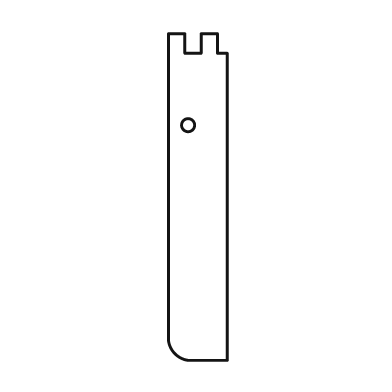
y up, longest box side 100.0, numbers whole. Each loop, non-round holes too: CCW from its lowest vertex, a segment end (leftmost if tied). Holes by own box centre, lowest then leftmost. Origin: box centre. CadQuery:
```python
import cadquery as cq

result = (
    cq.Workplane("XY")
    .moveTo(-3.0, -50.0)
    .lineTo(9.0, -50.0)
    .lineTo(9.0, 44.0)
    .lineTo(6.0, 44.0)
    .lineTo(6.0, 50.0)
    .lineTo(1.0, 50.0)
    .lineTo(1.0, 44.0)
    .lineTo(-4.0, 44.0)
    .lineTo(-4.0, 50.0)
    .lineTo(-9.0, 50.0)
    .lineTo(-9.0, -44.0)
    .threePointArc((-7.0, -48.0), (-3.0, -50.0))
    .close()
    .moveTo(-3.0, 22.0)
    .circle(2.0)
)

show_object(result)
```